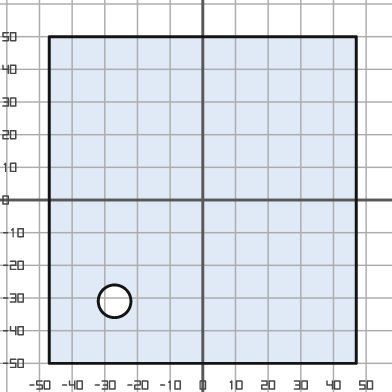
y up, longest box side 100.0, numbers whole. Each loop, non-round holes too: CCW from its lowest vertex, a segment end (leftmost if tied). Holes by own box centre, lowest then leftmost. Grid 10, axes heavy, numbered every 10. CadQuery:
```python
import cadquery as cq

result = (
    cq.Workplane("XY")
    .moveTo(-47.0, -50.0)
    .lineTo(47.0, -50.0)
    .lineTo(47.0, 50.0)
    .lineTo(-47.0, 50.0)
    .close()
    .moveTo(-27.0, -31.0)
    .circle(5.0)
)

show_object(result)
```